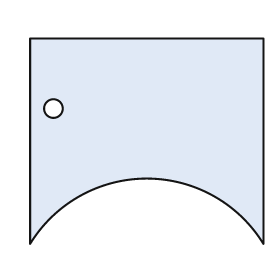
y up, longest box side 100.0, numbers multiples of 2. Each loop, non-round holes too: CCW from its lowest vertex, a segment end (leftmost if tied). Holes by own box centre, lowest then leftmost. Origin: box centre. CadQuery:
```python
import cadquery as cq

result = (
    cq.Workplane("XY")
    .moveTo(-50.0, -44.0)
    .threePointArc((0.0, -16.0), (50.0, -44.0))
    .lineTo(50.0, 44.0)
    .lineTo(-50.0, 44.0)
    .close()
    .moveTo(-40.0, 14.0)
    .circle(4.0)
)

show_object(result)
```